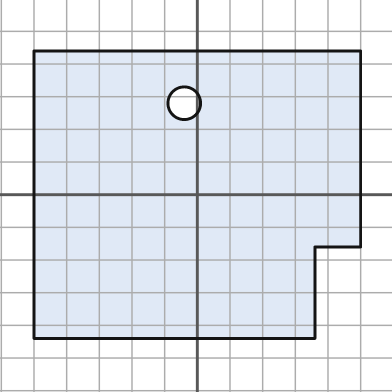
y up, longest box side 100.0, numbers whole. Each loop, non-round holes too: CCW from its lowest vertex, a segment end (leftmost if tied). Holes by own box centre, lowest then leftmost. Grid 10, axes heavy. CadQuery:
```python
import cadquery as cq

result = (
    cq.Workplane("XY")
    .moveTo(-50.0, -44.0)
    .lineTo(36.0, -44.0)
    .lineTo(36.0, -16.0)
    .lineTo(50.0, -16.0)
    .lineTo(50.0, 44.0)
    .lineTo(-50.0, 44.0)
    .close()
    .moveTo(-4.0, 28.0)
    .circle(5.0)
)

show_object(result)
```